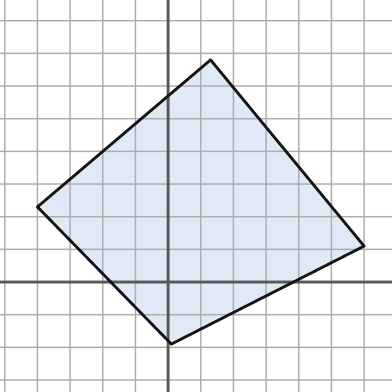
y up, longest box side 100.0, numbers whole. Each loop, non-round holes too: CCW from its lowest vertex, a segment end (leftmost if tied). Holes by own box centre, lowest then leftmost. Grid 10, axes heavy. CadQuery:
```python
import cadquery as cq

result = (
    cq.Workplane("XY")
    .moveTo(1.0, -19.0)
    .lineTo(60.0, 11.0)
    .lineTo(13.0, 68.0)
    .lineTo(-40.0, 23.0)
    .close()
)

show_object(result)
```